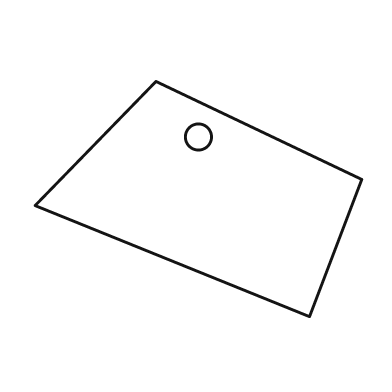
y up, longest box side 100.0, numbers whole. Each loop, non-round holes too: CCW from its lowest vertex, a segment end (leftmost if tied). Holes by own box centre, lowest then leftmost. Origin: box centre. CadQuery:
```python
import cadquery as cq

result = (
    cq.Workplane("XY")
    .moveTo(34.0, -36.0)
    .lineTo(50.0, 6.0)
    .lineTo(-13.0, 36.0)
    .lineTo(-50.0, -2.0)
    .close()
    .moveTo(0.0, 19.0)
    .circle(4.0)
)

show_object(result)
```